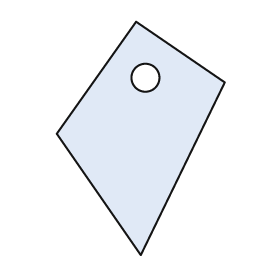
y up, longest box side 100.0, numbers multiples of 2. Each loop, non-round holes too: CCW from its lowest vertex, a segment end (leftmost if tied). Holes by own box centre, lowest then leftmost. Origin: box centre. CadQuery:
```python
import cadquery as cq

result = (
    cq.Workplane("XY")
    .moveTo(0.0, -50.0)
    .lineTo(36.0, 24.0)
    .lineTo(-2.0, 50.0)
    .lineTo(-36.0, 2.0)
    .close()
    .moveTo(2.0, 26.0)
    .circle(6.0)
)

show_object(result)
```